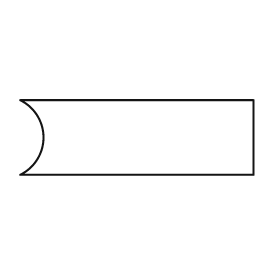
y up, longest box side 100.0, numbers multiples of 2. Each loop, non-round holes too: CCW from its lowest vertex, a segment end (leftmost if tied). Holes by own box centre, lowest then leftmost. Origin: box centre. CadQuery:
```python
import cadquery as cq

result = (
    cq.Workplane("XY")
    .moveTo(-50.0, -16.0)
    .lineTo(50.0, -16.0)
    .lineTo(50.0, 16.0)
    .lineTo(-50.0, 16.0)
    .threePointArc((-40.0, 0.0), (-50.0, -16.0))
    .close()
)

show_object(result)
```